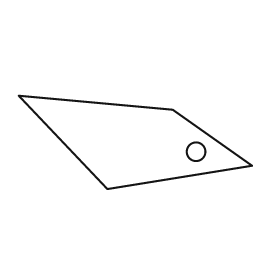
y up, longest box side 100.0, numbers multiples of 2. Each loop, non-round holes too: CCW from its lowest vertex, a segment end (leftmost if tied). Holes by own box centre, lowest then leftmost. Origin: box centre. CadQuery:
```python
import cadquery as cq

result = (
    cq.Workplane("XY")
    .moveTo(-12.0, -20.0)
    .lineTo(50.0, -10.0)
    .lineTo(16.0, 14.0)
    .lineTo(-50.0, 20.0)
    .close()
    .moveTo(26.0, -4.0)
    .circle(4.0)
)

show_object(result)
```